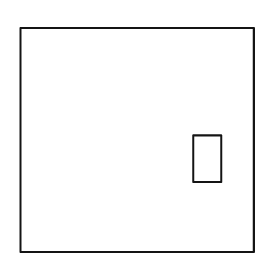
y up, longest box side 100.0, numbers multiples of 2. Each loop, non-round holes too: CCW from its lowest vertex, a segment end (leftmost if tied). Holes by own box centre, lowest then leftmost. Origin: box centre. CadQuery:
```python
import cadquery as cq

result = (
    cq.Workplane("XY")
    .moveTo(-50.0, -48.0)
    .lineTo(50.0, -48.0)
    .lineTo(50.0, 48.0)
    .lineTo(-50.0, 48.0)
    .close()
    .moveTo(24.0, -18.0)
    .lineTo(36.0, -18.0)
    .lineTo(36.0, 2.0)
    .lineTo(24.0, 2.0)
    .close()
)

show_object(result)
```